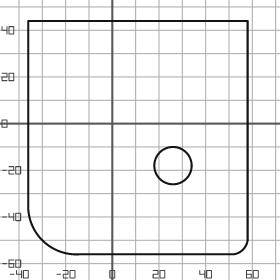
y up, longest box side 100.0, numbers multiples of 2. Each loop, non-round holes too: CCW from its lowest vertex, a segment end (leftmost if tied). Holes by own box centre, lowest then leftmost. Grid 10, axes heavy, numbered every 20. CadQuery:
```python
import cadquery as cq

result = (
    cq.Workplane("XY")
    .moveTo(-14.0, -56.0)
    .lineTo(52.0, -56.0)
    .threePointArc((56.0, -54.0), (58.0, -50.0))
    .lineTo(58.0, 44.0)
    .lineTo(-36.0, 44.0)
    .lineTo(-36.0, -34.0)
    .threePointArc((-30.0, -50.0), (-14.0, -56.0))
    .close()
    .moveTo(26.0, -18.0)
    .circle(8.0)
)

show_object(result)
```